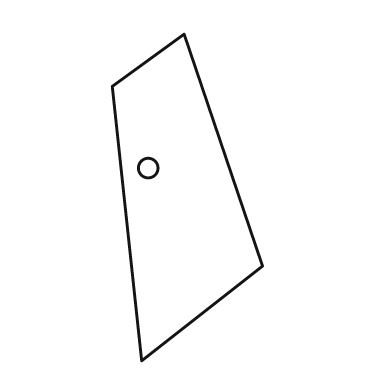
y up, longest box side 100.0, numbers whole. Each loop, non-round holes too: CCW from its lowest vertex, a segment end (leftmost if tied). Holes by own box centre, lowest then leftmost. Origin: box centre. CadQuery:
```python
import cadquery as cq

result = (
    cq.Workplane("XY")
    .moveTo(-14.0, -50.0)
    .lineTo(23.0, -21.0)
    .lineTo(-1.0, 50.0)
    .lineTo(-23.0, 34.0)
    .close()
    .moveTo(-12.0, 9.0)
    .circle(3.0)
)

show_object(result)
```